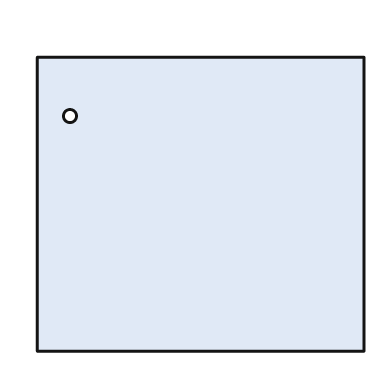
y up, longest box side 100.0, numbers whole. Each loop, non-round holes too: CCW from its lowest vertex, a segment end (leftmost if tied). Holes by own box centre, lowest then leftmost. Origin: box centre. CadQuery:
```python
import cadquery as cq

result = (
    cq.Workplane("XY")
    .moveTo(-50.0, -45.0)
    .lineTo(50.0, -45.0)
    .lineTo(50.0, 45.0)
    .lineTo(-50.0, 45.0)
    .close()
    .moveTo(-40.0, 27.0)
    .circle(2.0)
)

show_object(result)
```